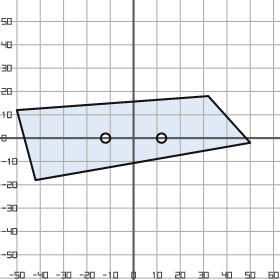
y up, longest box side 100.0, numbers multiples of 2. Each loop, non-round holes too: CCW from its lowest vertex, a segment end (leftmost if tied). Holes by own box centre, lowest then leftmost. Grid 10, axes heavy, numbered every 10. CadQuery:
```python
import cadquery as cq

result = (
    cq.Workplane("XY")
    .moveTo(-42.0, -18.0)
    .lineTo(50.0, -2.0)
    .lineTo(32.0, 18.0)
    .lineTo(-50.0, 12.0)
    .close()
    .moveTo(-12.0, 0.0)
    .circle(2.0)
    .moveTo(12.0, 0.0)
    .circle(2.0)
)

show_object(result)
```